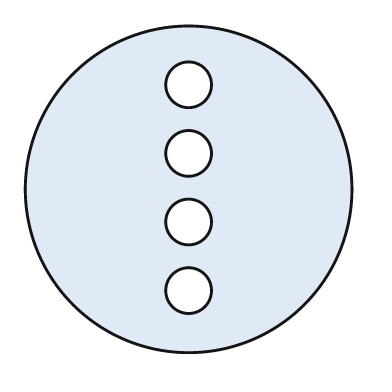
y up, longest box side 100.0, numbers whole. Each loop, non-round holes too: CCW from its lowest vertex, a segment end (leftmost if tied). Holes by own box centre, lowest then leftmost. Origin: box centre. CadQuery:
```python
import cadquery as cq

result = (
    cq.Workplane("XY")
    .moveTo(0.0, 0.0)
    .circle(50.0)
    .moveTo(0.0, -31.0)
    .circle(7.0)
    .moveTo(0.0, -10.0)
    .circle(7.0)
    .moveTo(0.0, 11.0)
    .circle(7.0)
    .moveTo(0.0, 32.0)
    .circle(7.0)
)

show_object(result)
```